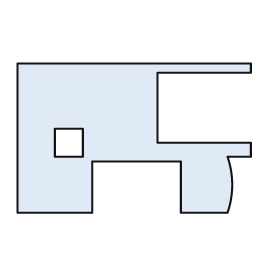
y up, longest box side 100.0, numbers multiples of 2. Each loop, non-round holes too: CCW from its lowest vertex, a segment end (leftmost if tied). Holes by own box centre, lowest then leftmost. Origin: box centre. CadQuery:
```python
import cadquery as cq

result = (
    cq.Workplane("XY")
    .moveTo(-50.0, -32.0)
    .lineTo(-18.0, -32.0)
    .lineTo(-18.0, -10.0)
    .lineTo(20.0, -10.0)
    .lineTo(20.0, -32.0)
    .lineTo(40.0, -32.0)
    .threePointArc((42.0, -20.0), (40.0, -8.0))
    .lineTo(50.0, -8.0)
    .lineTo(50.0, -2.0)
    .lineTo(10.0, -2.0)
    .lineTo(10.0, 28.0)
    .lineTo(50.0, 28.0)
    .lineTo(50.0, 32.0)
    .lineTo(-50.0, 32.0)
    .close()
    .moveTo(-34.0, -8.0)
    .lineTo(-22.0, -8.0)
    .lineTo(-22.0, 4.0)
    .lineTo(-34.0, 4.0)
    .close()
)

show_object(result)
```